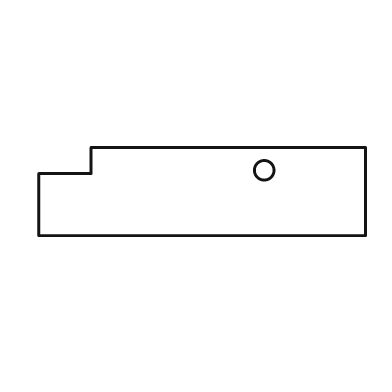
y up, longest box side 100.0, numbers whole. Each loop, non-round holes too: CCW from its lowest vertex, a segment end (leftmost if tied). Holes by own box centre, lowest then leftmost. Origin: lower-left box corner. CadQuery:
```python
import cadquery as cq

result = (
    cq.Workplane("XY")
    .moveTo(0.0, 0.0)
    .lineTo(100.0, 0.0)
    .lineTo(100.0, 27.0)
    .lineTo(16.0, 27.0)
    .lineTo(16.0, 19.0)
    .lineTo(0.0, 19.0)
    .close()
    .moveTo(69.0, 20.0)
    .circle(3.0)
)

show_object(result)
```